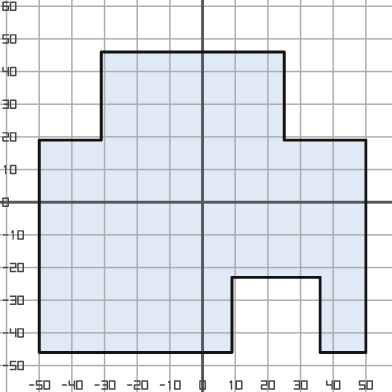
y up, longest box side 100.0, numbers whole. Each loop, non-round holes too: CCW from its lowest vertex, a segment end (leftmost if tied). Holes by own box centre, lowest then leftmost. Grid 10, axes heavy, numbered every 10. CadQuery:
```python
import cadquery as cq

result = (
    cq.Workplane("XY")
    .moveTo(-50.0, -46.0)
    .lineTo(9.0, -46.0)
    .lineTo(9.0, -23.0)
    .lineTo(36.0, -23.0)
    .lineTo(36.0, -46.0)
    .lineTo(50.0, -46.0)
    .lineTo(50.0, 19.0)
    .lineTo(25.0, 19.0)
    .lineTo(25.0, 46.0)
    .lineTo(-31.0, 46.0)
    .lineTo(-31.0, 19.0)
    .lineTo(-50.0, 19.0)
    .close()
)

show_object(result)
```